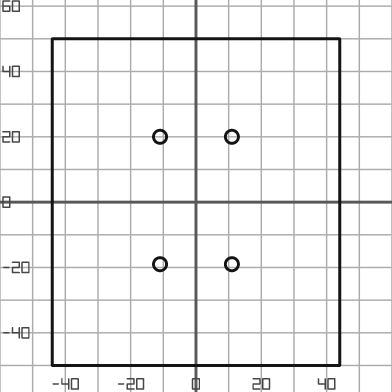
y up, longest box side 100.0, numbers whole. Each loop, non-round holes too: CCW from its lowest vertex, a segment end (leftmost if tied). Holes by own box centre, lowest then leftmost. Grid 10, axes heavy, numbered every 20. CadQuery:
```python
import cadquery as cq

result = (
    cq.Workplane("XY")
    .moveTo(-44.0, -50.0)
    .lineTo(44.0, -50.0)
    .lineTo(44.0, 50.0)
    .lineTo(-44.0, 50.0)
    .close()
    .moveTo(-11.0, -19.0)
    .circle(2.0)
    .moveTo(11.0, -19.0)
    .circle(2.0)
    .moveTo(-11.0, 20.0)
    .circle(2.0)
    .moveTo(11.0, 20.0)
    .circle(2.0)
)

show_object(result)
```